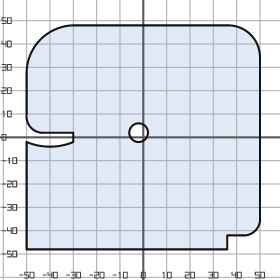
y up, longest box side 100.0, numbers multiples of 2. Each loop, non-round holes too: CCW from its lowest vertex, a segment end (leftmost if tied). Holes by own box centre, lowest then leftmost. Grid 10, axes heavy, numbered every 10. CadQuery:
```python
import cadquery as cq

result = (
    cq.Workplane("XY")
    .moveTo(-50.0, -48.0)
    .lineTo(36.0, -48.0)
    .lineTo(36.0, -42.0)
    .lineTo(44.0, -42.0)
    .threePointArc((48.0, -40.0), (50.0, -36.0))
    .lineTo(50.0, 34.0)
    .threePointArc((46.0, 44.0), (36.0, 48.0))
    .lineTo(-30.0, 48.0)
    .threePointArc((-44.0, 42.0), (-50.0, 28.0))
    .lineTo(-50.0, 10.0)
    .threePointArc((-48.0, 4.0), (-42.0, 2.0))
    .lineTo(-30.0, 2.0)
    .lineTo(-30.0, -2.0)
    .threePointArc((-40.0, -4.0), (-50.0, -2.0))
    .close()
    .moveTo(-2.0, 2.0)
    .circle(4.0)
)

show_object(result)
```